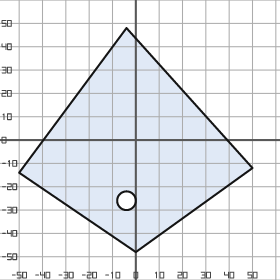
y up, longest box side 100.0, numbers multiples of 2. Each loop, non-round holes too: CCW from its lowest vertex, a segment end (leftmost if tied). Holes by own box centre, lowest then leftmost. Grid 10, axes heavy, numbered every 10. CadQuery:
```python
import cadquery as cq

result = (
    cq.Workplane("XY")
    .moveTo(0.0, -48.0)
    .lineTo(50.0, -12.0)
    .lineTo(-4.0, 48.0)
    .lineTo(-50.0, -14.0)
    .close()
    .moveTo(-4.0, -26.0)
    .circle(4.0)
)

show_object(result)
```